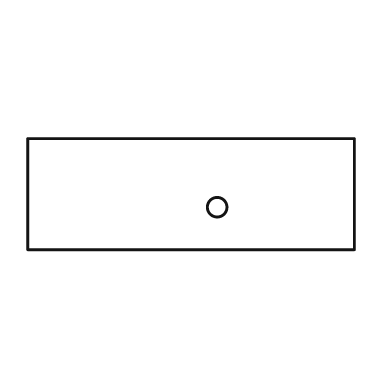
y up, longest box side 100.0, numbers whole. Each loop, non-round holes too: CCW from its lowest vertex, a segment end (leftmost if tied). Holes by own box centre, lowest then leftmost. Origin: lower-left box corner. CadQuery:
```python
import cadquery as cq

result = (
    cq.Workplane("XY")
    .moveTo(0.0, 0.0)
    .lineTo(100.0, 0.0)
    .lineTo(100.0, 34.0)
    .lineTo(0.0, 34.0)
    .close()
    .moveTo(58.0, 13.0)
    .circle(3.0)
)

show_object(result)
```